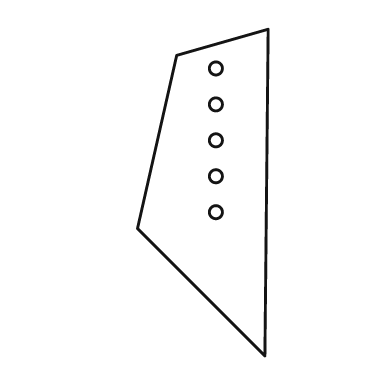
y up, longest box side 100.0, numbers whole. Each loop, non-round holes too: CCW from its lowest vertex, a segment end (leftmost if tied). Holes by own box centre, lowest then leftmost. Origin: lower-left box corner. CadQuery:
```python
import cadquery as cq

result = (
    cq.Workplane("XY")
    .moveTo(39.0, 0.0)
    .lineTo(40.0, 100.0)
    .lineTo(12.0, 92.0)
    .lineTo(0.0, 39.0)
    .close()
    .moveTo(24.0, 44.0)
    .circle(2.0)
    .moveTo(24.0, 55.0)
    .circle(2.0)
    .moveTo(24.0, 66.0)
    .circle(2.0)
    .moveTo(24.0, 77.0)
    .circle(2.0)
    .moveTo(24.0, 88.0)
    .circle(2.0)
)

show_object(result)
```